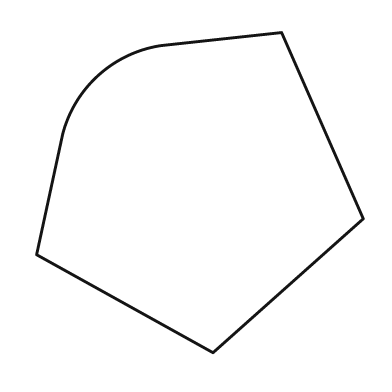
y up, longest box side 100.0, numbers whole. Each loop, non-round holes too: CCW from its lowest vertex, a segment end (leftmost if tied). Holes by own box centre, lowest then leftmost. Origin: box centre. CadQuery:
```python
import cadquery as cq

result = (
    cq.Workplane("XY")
    .moveTo(4.0, -49.0)
    .lineTo(50.0, -8.0)
    .lineTo(25.0, 49.0)
    .lineTo(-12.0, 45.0)
    .threePointArc((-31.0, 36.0), (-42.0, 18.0))
    .lineTo(-50.0, -19.0)
    .close()
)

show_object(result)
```